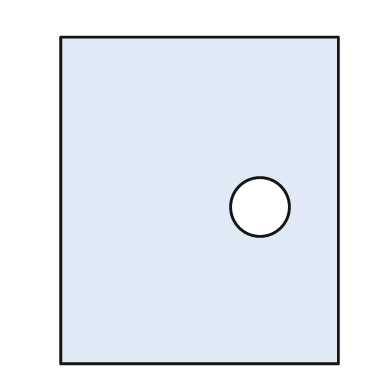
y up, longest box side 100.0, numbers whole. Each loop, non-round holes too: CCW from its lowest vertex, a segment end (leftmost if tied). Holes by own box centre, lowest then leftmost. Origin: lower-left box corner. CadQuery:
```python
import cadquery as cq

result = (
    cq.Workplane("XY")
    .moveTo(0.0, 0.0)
    .lineTo(85.0, 0.0)
    .lineTo(85.0, 100.0)
    .lineTo(0.0, 100.0)
    .close()
    .moveTo(61.0, 48.0)
    .circle(9.0)
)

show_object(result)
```